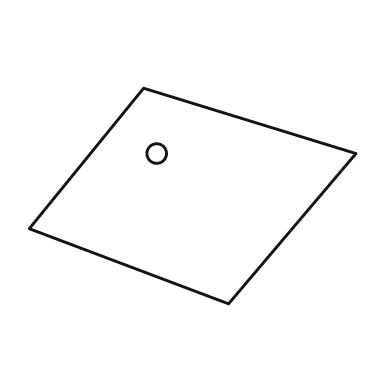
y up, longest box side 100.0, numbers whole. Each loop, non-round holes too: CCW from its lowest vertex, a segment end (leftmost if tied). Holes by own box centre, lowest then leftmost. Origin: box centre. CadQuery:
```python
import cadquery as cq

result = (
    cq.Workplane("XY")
    .moveTo(11.0, -33.0)
    .lineTo(50.0, 13.0)
    .lineTo(-15.0, 33.0)
    .lineTo(-50.0, -10.0)
    .close()
    .moveTo(-11.0, 13.0)
    .circle(3.0)
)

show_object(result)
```